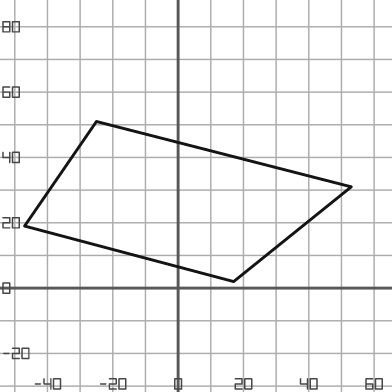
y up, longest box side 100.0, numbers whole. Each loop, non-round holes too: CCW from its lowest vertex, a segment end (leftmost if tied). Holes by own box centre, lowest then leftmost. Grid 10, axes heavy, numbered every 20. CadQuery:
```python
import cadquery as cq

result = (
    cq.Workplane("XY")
    .moveTo(17.0, 2.0)
    .lineTo(53.0, 31.0)
    .lineTo(-25.0, 51.0)
    .lineTo(-47.0, 19.0)
    .close()
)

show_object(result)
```